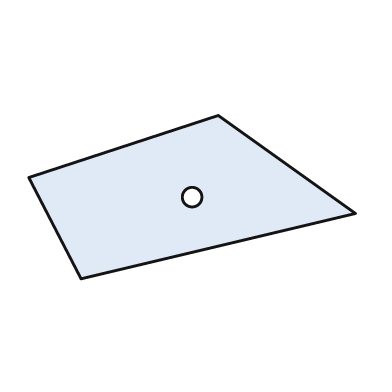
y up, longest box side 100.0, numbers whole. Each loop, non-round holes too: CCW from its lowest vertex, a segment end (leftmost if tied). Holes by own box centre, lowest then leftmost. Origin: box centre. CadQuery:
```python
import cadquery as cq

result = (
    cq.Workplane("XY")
    .moveTo(-34.0, -25.0)
    .lineTo(50.0, -5.0)
    .lineTo(8.0, 25.0)
    .lineTo(-50.0, 6.0)
    .close()
    .moveTo(0.0, 0.0)
    .circle(3.0)
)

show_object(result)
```